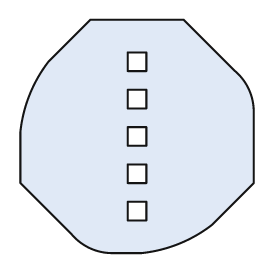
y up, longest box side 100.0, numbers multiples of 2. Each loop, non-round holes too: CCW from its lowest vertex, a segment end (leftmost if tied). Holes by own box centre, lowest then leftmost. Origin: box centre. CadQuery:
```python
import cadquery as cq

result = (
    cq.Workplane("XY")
    .moveTo(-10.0, -50.0)
    .lineTo(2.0, -50.0)
    .threePointArc((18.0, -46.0), (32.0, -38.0))
    .lineTo(50.0, -20.0)
    .lineTo(50.0, 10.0)
    .threePointArc((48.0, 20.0), (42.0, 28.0))
    .lineTo(20.0, 50.0)
    .lineTo(-20.0, 50.0)
    .lineTo(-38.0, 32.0)
    .threePointArc((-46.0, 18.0), (-50.0, 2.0))
    .lineTo(-50.0, -20.0)
    .lineTo(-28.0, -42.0)
    .threePointArc((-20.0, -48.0), (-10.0, -50.0))
    .close()
    .moveTo(-4.0, -36.0)
    .lineTo(4.0, -36.0)
    .lineTo(4.0, -28.0)
    .lineTo(-4.0, -28.0)
    .close()
    .moveTo(-4.0, -20.0)
    .lineTo(4.0, -20.0)
    .lineTo(4.0, -12.0)
    .lineTo(-4.0, -12.0)
    .close()
    .moveTo(-4.0, -4.0)
    .lineTo(4.0, -4.0)
    .lineTo(4.0, 4.0)
    .lineTo(-4.0, 4.0)
    .close()
    .moveTo(-4.0, 12.0)
    .lineTo(4.0, 12.0)
    .lineTo(4.0, 20.0)
    .lineTo(-4.0, 20.0)
    .close()
    .moveTo(-4.0, 28.0)
    .lineTo(4.0, 28.0)
    .lineTo(4.0, 36.0)
    .lineTo(-4.0, 36.0)
    .close()
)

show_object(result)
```